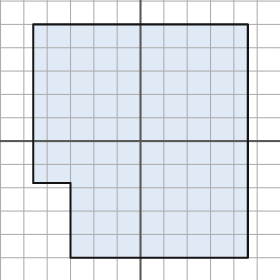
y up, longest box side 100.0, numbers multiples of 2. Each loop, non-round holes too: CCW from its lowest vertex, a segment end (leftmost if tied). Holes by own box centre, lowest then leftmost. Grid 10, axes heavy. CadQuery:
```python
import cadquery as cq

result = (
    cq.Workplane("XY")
    .moveTo(-30.0, -50.0)
    .lineTo(46.0, -50.0)
    .lineTo(46.0, 50.0)
    .lineTo(-46.0, 50.0)
    .lineTo(-46.0, -18.0)
    .lineTo(-30.0, -18.0)
    .close()
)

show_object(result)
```